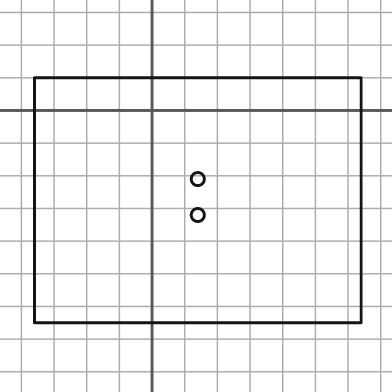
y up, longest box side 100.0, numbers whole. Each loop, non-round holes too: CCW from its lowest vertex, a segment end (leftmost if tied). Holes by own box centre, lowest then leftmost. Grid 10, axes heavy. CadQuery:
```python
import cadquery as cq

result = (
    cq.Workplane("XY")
    .moveTo(-36.0, -65.0)
    .lineTo(64.0, -65.0)
    .lineTo(64.0, 10.0)
    .lineTo(-36.0, 10.0)
    .close()
    .moveTo(14.0, -32.0)
    .circle(2.0)
    .moveTo(14.0, -21.0)
    .circle(2.0)
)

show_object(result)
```